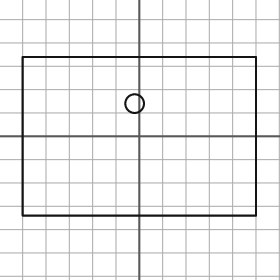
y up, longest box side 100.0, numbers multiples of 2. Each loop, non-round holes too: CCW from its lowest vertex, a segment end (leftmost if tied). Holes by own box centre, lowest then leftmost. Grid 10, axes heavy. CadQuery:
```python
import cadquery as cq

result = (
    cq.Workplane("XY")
    .moveTo(-50.0, -34.0)
    .lineTo(50.0, -34.0)
    .lineTo(50.0, 34.0)
    .lineTo(-50.0, 34.0)
    .close()
    .moveTo(-2.0, 14.0)
    .circle(4.0)
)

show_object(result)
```